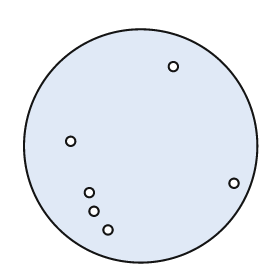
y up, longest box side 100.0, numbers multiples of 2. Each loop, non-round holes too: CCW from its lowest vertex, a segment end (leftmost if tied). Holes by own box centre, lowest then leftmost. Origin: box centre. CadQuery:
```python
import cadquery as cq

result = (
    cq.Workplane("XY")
    .moveTo(0.0, 0.0)
    .circle(50.0)
    .moveTo(-14.0, -36.0)
    .circle(2.0)
    .moveTo(-20.0, -28.0)
    .circle(2.0)
    .moveTo(-22.0, -20.0)
    .circle(2.0)
    .moveTo(40.0, -16.0)
    .circle(2.0)
    .moveTo(-30.0, 2.0)
    .circle(2.0)
    .moveTo(14.0, 34.0)
    .circle(2.0)
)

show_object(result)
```